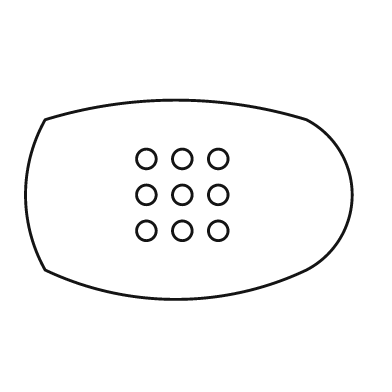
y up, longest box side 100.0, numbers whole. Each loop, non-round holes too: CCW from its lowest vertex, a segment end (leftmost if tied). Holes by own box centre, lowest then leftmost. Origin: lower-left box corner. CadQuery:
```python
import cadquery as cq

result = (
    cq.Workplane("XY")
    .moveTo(6.0, 9.0)
    .threePointArc((46.0, 0.0), (86.0, 9.0))
    .threePointArc((100.0, 32.0), (86.0, 55.0))
    .threePointArc((46.0, 61.0), (6.0, 55.0))
    .threePointArc((0.0, 32.0), (6.0, 9.0))
    .close()
    .moveTo(37.0, 21.0)
    .circle(3.0)
    .moveTo(48.0, 21.0)
    .circle(3.0)
    .moveTo(59.0, 21.0)
    .circle(3.0)
    .moveTo(37.0, 32.0)
    .circle(3.0)
    .moveTo(48.0, 32.0)
    .circle(3.0)
    .moveTo(59.0, 32.0)
    .circle(3.0)
    .moveTo(37.0, 43.0)
    .circle(3.0)
    .moveTo(48.0, 43.0)
    .circle(3.0)
    .moveTo(59.0, 43.0)
    .circle(3.0)
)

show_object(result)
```